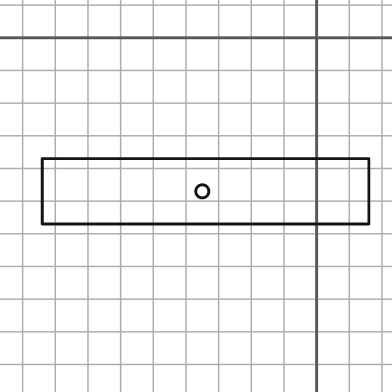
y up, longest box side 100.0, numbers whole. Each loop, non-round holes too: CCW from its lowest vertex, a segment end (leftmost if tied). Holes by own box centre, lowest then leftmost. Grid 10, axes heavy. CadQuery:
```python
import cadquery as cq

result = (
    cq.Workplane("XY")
    .moveTo(-84.0, -57.0)
    .lineTo(16.0, -57.0)
    .lineTo(16.0, -37.0)
    .lineTo(-84.0, -37.0)
    .close()
    .moveTo(-35.0, -47.0)
    .circle(2.0)
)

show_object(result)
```